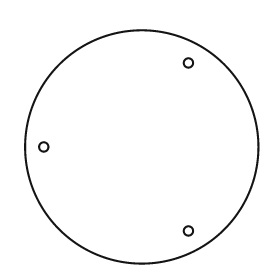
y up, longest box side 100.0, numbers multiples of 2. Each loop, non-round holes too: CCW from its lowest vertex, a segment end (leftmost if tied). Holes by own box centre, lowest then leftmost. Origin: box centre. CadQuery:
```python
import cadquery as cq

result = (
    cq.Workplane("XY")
    .moveTo(0.0, 0.0)
    .circle(50.0)
    .moveTo(20.0, -36.0)
    .circle(2.0)
    .moveTo(-42.0, 0.0)
    .circle(2.0)
    .moveTo(20.0, 36.0)
    .circle(2.0)
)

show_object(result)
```